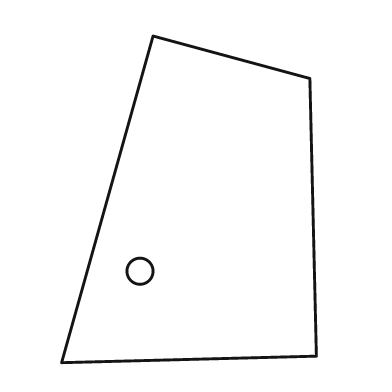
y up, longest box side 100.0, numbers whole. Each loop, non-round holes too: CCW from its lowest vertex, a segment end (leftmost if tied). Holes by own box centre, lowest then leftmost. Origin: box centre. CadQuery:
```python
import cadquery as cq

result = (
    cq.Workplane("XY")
    .moveTo(-39.0, -50.0)
    .lineTo(39.0, -48.0)
    .lineTo(37.0, 37.0)
    .lineTo(-11.0, 50.0)
    .close()
    .moveTo(-15.0, -22.0)
    .circle(4.0)
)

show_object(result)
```